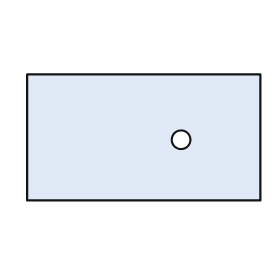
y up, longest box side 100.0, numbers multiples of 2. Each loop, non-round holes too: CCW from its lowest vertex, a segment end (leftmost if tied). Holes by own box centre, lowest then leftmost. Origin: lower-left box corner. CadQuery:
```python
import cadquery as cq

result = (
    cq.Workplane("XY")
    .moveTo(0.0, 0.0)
    .lineTo(100.0, 0.0)
    .lineTo(100.0, 54.0)
    .lineTo(0.0, 54.0)
    .close()
    .moveTo(66.0, 26.0)
    .circle(4.0)
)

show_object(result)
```